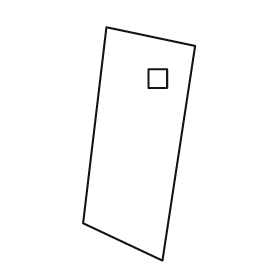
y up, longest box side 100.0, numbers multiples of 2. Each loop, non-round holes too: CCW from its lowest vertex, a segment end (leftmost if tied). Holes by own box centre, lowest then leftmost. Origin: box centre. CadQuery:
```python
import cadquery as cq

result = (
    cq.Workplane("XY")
    .moveTo(10.0, -50.0)
    .lineTo(24.0, 42.0)
    .lineTo(-14.0, 50.0)
    .lineTo(-24.0, -34.0)
    .close()
    .moveTo(4.0, 24.0)
    .lineTo(12.0, 24.0)
    .lineTo(12.0, 32.0)
    .lineTo(4.0, 32.0)
    .close()
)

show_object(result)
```